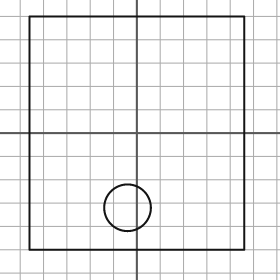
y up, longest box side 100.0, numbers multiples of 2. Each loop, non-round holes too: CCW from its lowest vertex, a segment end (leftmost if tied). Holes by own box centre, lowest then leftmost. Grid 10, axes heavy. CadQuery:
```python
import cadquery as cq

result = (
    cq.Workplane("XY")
    .moveTo(-46.0, -50.0)
    .lineTo(46.0, -50.0)
    .lineTo(46.0, 50.0)
    .lineTo(-46.0, 50.0)
    .close()
    .moveTo(-4.0, -32.0)
    .circle(10.0)
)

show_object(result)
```